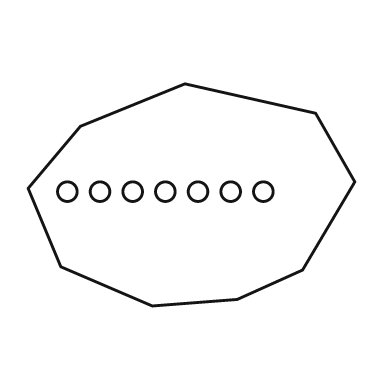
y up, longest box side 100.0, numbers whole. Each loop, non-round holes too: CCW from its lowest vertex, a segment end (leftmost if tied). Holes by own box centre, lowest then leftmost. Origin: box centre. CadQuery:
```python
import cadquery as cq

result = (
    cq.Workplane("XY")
    .moveTo(-12.0, -34.0)
    .lineTo(14.0, -32.0)
    .lineTo(34.0, -23.0)
    .lineTo(50.0, 4.0)
    .lineTo(38.0, 25.0)
    .lineTo(-2.0, 34.0)
    .lineTo(-34.0, 21.0)
    .lineTo(-50.0, 2.0)
    .lineTo(-40.0, -22.0)
    .close()
    .moveTo(-38.0, 1.0)
    .circle(3.0)
    .moveTo(-28.0, 1.0)
    .circle(3.0)
    .moveTo(-18.0, 1.0)
    .circle(3.0)
    .moveTo(-8.0, 1.0)
    .circle(3.0)
    .moveTo(2.0, 1.0)
    .circle(3.0)
    .moveTo(12.0, 1.0)
    .circle(3.0)
    .moveTo(22.0, 1.0)
    .circle(3.0)
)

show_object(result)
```